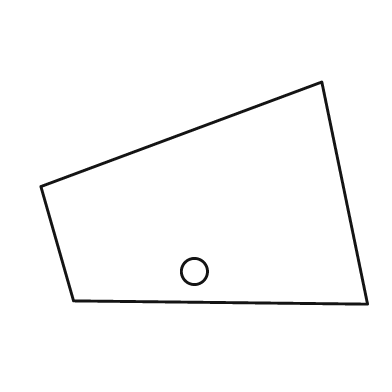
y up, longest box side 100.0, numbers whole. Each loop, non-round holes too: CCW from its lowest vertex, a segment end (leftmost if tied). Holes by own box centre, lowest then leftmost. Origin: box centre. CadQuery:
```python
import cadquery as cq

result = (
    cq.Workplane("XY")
    .moveTo(50.0, -34.0)
    .lineTo(36.0, 34.0)
    .lineTo(-50.0, 2.0)
    .lineTo(-40.0, -33.0)
    .close()
    .moveTo(-3.0, -24.0)
    .circle(4.0)
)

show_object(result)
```